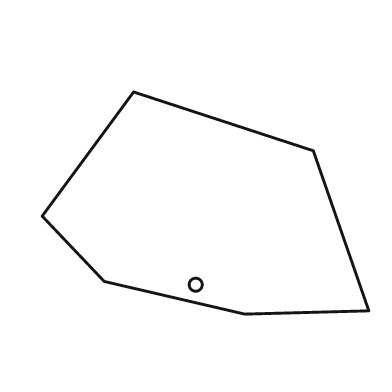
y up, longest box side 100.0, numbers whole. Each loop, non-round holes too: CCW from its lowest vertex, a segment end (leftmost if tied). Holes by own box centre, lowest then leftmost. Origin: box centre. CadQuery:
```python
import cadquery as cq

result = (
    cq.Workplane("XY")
    .moveTo(12.0, -34.0)
    .lineTo(50.0, -33.0)
    .lineTo(33.0, 16.0)
    .lineTo(-22.0, 34.0)
    .lineTo(-50.0, -4.0)
    .lineTo(-31.0, -24.0)
    .close()
    .moveTo(-3.0, -25.0)
    .circle(2.0)
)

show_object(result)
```